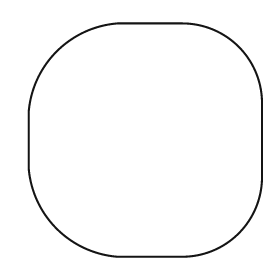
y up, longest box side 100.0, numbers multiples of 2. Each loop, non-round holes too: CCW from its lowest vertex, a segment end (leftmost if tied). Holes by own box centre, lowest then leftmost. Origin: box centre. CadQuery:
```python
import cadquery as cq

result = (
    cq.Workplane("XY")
    .moveTo(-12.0, -50.0)
    .lineTo(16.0, -50.0)
    .threePointArc((40.0, -40.0), (50.0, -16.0))
    .lineTo(50.0, 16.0)
    .threePointArc((40.0, 40.0), (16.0, 50.0))
    .lineTo(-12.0, 50.0)
    .threePointArc((-38.0, 38.0), (-50.0, 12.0))
    .lineTo(-50.0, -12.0)
    .threePointArc((-38.0, -38.0), (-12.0, -50.0))
    .close()
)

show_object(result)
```